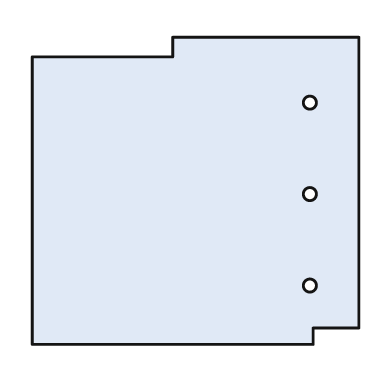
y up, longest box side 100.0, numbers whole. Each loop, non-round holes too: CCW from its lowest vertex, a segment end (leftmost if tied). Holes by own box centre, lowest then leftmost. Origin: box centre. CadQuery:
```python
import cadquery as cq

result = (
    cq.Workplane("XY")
    .moveTo(-50.0, -47.0)
    .lineTo(36.0, -47.0)
    .lineTo(36.0, -42.0)
    .lineTo(50.0, -42.0)
    .lineTo(50.0, 47.0)
    .lineTo(-7.0, 47.0)
    .lineTo(-7.0, 41.0)
    .lineTo(-50.0, 41.0)
    .close()
    .moveTo(35.0, -29.0)
    .circle(2.0)
    .moveTo(35.0, -1.0)
    .circle(2.0)
    .moveTo(35.0, 27.0)
    .circle(2.0)
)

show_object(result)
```